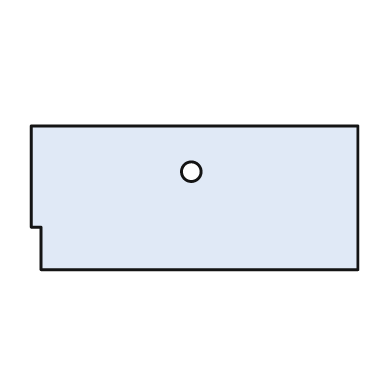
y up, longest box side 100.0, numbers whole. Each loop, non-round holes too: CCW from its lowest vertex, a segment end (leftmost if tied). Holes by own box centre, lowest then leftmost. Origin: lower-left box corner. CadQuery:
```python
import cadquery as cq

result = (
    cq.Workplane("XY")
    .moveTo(3.0, 0.0)
    .lineTo(100.0, 0.0)
    .lineTo(100.0, 44.0)
    .lineTo(0.0, 44.0)
    .lineTo(0.0, 13.0)
    .lineTo(3.0, 13.0)
    .close()
    .moveTo(49.0, 30.0)
    .circle(3.0)
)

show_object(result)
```